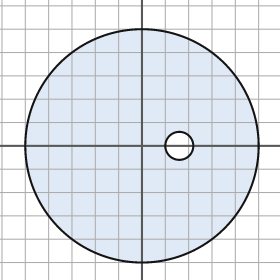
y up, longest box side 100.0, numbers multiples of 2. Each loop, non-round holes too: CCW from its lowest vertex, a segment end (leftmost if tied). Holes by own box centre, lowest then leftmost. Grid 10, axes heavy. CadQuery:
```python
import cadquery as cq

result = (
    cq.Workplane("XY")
    .moveTo(0.0, 0.0)
    .circle(50.0)
    .moveTo(16.0, 0.0)
    .circle(6.0)
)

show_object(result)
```